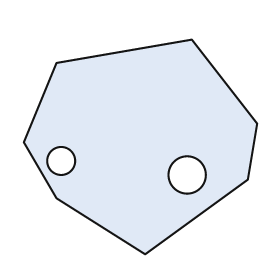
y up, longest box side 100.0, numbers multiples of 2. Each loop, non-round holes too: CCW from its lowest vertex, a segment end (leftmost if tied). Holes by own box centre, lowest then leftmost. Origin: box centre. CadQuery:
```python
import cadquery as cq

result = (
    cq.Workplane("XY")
    .moveTo(2.0, -46.0)
    .lineTo(46.0, -14.0)
    .lineTo(50.0, 10.0)
    .lineTo(22.0, 46.0)
    .lineTo(-36.0, 36.0)
    .lineTo(-50.0, 2.0)
    .lineTo(-36.0, -22.0)
    .close()
    .moveTo(20.0, -12.0)
    .circle(8.0)
    .moveTo(-34.0, -6.0)
    .circle(6.0)
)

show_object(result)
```